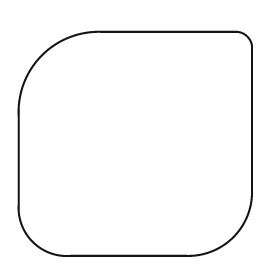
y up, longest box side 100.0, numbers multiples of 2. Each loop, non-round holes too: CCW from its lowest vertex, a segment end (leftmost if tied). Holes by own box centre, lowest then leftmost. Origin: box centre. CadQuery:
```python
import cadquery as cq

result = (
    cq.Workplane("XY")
    .moveTo(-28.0, -48.0)
    .lineTo(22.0, -48.0)
    .threePointArc((42.0, -40.0), (50.0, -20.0))
    .lineTo(50.0, 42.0)
    .threePointArc((48.0, 46.0), (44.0, 48.0))
    .lineTo(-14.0, 48.0)
    .threePointArc((-40.0, 38.0), (-50.0, 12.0))
    .lineTo(-50.0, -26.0)
    .threePointArc((-44.0, -42.0), (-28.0, -48.0))
    .close()
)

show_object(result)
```